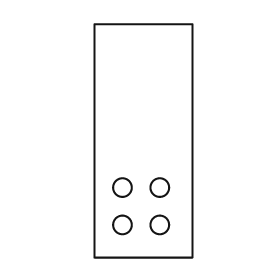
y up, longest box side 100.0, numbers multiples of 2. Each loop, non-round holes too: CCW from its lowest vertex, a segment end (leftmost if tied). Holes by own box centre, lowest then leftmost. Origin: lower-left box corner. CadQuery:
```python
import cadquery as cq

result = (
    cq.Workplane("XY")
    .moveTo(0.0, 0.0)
    .lineTo(42.0, 0.0)
    .lineTo(42.0, 100.0)
    .lineTo(0.0, 100.0)
    .close()
    .moveTo(12.0, 14.0)
    .circle(4.0)
    .moveTo(28.0, 14.0)
    .circle(4.0)
    .moveTo(12.0, 30.0)
    .circle(4.0)
    .moveTo(28.0, 30.0)
    .circle(4.0)
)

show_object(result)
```